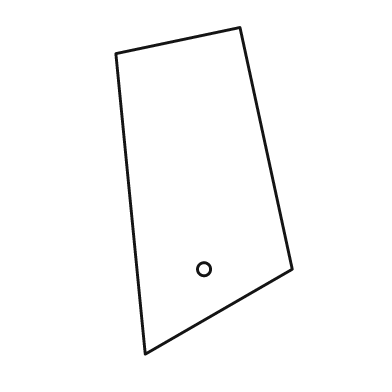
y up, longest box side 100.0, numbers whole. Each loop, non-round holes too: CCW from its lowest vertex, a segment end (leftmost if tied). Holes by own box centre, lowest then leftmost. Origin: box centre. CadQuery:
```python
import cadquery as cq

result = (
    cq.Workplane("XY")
    .moveTo(-18.0, -50.0)
    .lineTo(27.0, -24.0)
    .lineTo(11.0, 50.0)
    .lineTo(-27.0, 42.0)
    .close()
    .moveTo(0.0, -24.0)
    .circle(2.0)
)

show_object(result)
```